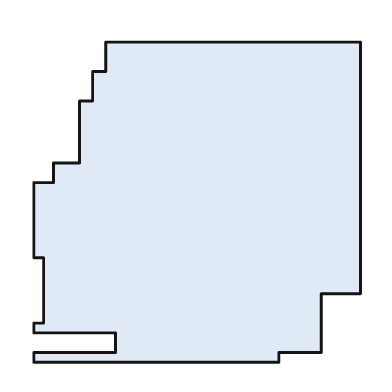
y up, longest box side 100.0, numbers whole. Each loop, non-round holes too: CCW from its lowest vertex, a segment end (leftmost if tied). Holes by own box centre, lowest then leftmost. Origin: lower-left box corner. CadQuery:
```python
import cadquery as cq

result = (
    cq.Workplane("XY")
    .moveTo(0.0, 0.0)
    .lineTo(75.0, 0.0)
    .lineTo(75.0, 3.0)
    .lineTo(88.0, 3.0)
    .lineTo(88.0, 21.0)
    .lineTo(100.0, 21.0)
    .lineTo(100.0, 98.0)
    .lineTo(22.0, 98.0)
    .lineTo(22.0, 89.0)
    .lineTo(18.0, 89.0)
    .lineTo(18.0, 80.0)
    .lineTo(14.0, 80.0)
    .lineTo(14.0, 61.0)
    .lineTo(6.0, 61.0)
    .lineTo(6.0, 55.0)
    .lineTo(0.0, 55.0)
    .lineTo(0.0, 32.0)
    .lineTo(3.0, 32.0)
    .lineTo(3.0, 12.0)
    .lineTo(0.0, 12.0)
    .lineTo(0.0, 9.0)
    .lineTo(25.0, 9.0)
    .lineTo(25.0, 3.0)
    .lineTo(0.0, 3.0)
    .close()
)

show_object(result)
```